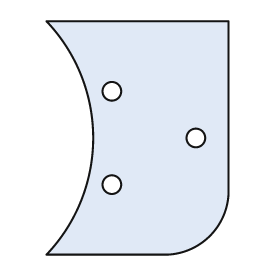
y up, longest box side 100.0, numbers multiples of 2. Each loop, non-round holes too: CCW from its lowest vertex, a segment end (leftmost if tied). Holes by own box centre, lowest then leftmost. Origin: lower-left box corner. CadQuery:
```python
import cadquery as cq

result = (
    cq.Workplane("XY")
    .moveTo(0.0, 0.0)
    .lineTo(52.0, 0.0)
    .threePointArc((70.0, 8.0), (78.0, 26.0))
    .lineTo(78.0, 100.0)
    .lineTo(0.0, 100.0)
    .threePointArc((20.0, 50.0), (0.0, 0.0))
    .close()
    .moveTo(28.0, 30.0)
    .circle(4.0)
    .moveTo(64.0, 50.0)
    .circle(4.0)
    .moveTo(28.0, 70.0)
    .circle(4.0)
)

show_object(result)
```